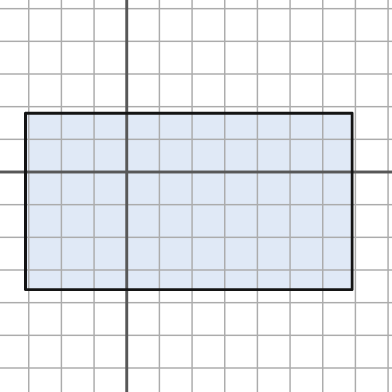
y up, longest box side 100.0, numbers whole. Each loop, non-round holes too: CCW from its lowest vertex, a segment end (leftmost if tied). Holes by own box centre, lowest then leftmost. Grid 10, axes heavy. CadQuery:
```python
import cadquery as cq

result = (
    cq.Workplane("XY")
    .moveTo(-31.0, -36.0)
    .lineTo(69.0, -36.0)
    .lineTo(69.0, 18.0)
    .lineTo(-31.0, 18.0)
    .close()
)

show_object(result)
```